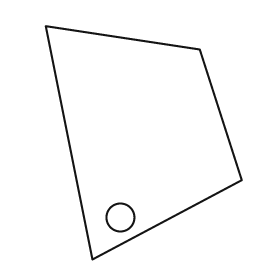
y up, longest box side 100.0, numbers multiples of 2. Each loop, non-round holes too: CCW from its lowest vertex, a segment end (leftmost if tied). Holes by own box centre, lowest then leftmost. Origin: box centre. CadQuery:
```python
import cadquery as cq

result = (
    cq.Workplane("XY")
    .moveTo(-22.0, -50.0)
    .lineTo(42.0, -16.0)
    .lineTo(24.0, 40.0)
    .lineTo(-42.0, 50.0)
    .close()
    .moveTo(-10.0, -32.0)
    .circle(6.0)
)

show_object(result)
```